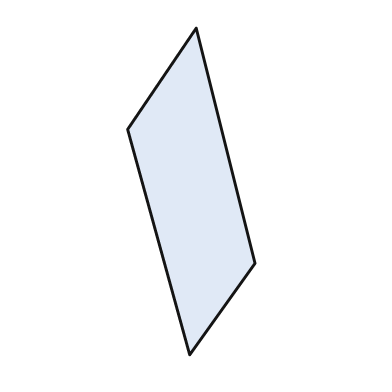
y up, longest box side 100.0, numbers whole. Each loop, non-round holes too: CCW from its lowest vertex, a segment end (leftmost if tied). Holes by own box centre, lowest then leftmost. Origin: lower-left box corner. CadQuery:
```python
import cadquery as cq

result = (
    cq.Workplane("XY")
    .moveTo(19.0, 0.0)
    .lineTo(39.0, 28.0)
    .lineTo(21.0, 100.0)
    .lineTo(0.0, 69.0)
    .close()
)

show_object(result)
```